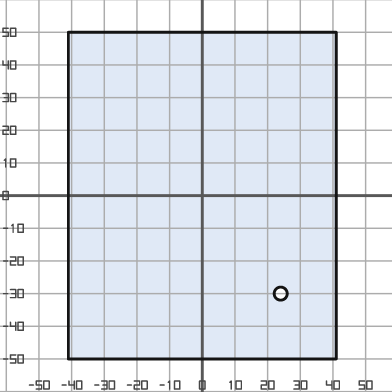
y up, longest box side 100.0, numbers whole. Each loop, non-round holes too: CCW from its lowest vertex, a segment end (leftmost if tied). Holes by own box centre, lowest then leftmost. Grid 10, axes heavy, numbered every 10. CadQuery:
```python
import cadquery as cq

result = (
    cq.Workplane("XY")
    .moveTo(-41.0, -50.0)
    .lineTo(41.0, -50.0)
    .lineTo(41.0, 50.0)
    .lineTo(-41.0, 50.0)
    .close()
    .moveTo(24.0, -30.0)
    .circle(2.0)
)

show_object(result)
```